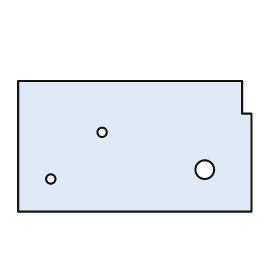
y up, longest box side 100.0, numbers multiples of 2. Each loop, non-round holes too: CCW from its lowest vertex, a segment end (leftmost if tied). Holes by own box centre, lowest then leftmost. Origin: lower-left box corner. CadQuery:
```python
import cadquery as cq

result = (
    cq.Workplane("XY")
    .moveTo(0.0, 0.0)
    .lineTo(100.0, 0.0)
    .lineTo(100.0, 42.0)
    .lineTo(96.0, 42.0)
    .lineTo(96.0, 56.0)
    .lineTo(0.0, 56.0)
    .close()
    .moveTo(14.0, 14.0)
    .circle(2.0)
    .moveTo(80.0, 18.0)
    .circle(4.0)
    .moveTo(36.0, 34.0)
    .circle(2.0)
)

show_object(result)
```